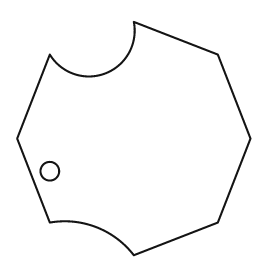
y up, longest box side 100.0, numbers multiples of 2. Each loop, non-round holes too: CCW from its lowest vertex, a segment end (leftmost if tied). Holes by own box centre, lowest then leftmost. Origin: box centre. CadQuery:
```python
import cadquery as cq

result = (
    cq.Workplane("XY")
    .moveTo(0.0, -50.0)
    .lineTo(36.0, -36.0)
    .lineTo(50.0, 0.0)
    .lineTo(36.0, 36.0)
    .lineTo(0.0, 50.0)
    .threePointArc((-12.0, 28.0), (-36.0, 36.0))
    .lineTo(-50.0, 0.0)
    .lineTo(-36.0, -36.0)
    .threePointArc((-16.0, -38.0), (0.0, -50.0))
    .close()
    .moveTo(-36.0, -14.0)
    .circle(4.0)
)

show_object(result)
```